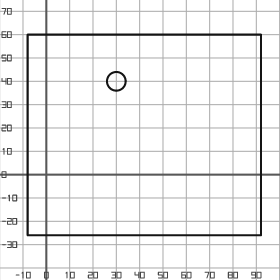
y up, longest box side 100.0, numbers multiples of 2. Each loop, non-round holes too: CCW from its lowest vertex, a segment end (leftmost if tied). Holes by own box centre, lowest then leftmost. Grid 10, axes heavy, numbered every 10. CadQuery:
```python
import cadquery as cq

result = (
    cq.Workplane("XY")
    .moveTo(-8.0, -26.0)
    .lineTo(92.0, -26.0)
    .lineTo(92.0, 60.0)
    .lineTo(-8.0, 60.0)
    .close()
    .moveTo(30.0, 40.0)
    .circle(4.0)
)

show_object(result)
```